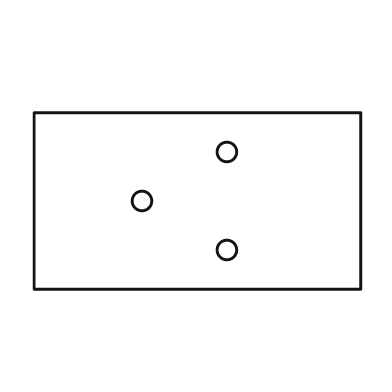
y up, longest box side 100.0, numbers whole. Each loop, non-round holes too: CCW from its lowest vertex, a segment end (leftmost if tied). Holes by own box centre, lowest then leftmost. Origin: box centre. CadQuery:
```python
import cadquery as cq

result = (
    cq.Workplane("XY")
    .moveTo(-50.0, -27.0)
    .lineTo(50.0, -27.0)
    .lineTo(50.0, 27.0)
    .lineTo(-50.0, 27.0)
    .close()
    .moveTo(9.0, -15.0)
    .circle(3.0)
    .moveTo(-17.0, 0.0)
    .circle(3.0)
    .moveTo(9.0, 15.0)
    .circle(3.0)
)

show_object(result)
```